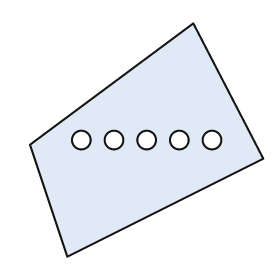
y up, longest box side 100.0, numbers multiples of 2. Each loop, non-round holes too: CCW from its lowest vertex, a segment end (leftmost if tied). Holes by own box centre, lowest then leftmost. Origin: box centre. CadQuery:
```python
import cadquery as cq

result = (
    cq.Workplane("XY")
    .moveTo(-34.0, -50.0)
    .lineTo(50.0, -8.0)
    .lineTo(20.0, 50.0)
    .lineTo(-50.0, -2.0)
    .close()
    .moveTo(-28.0, 0.0)
    .circle(4.0)
    .moveTo(-14.0, 0.0)
    .circle(4.0)
    .moveTo(0.0, 0.0)
    .circle(4.0)
    .moveTo(14.0, 0.0)
    .circle(4.0)
    .moveTo(28.0, 0.0)
    .circle(4.0)
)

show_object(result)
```